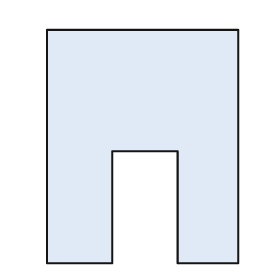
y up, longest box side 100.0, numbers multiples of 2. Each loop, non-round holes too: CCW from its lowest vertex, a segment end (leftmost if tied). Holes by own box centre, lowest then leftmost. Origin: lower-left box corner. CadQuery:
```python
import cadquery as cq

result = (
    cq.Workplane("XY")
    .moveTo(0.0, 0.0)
    .lineTo(28.0, 0.0)
    .lineTo(28.0, 48.0)
    .lineTo(56.0, 48.0)
    .lineTo(56.0, 0.0)
    .lineTo(82.0, 0.0)
    .lineTo(82.0, 100.0)
    .lineTo(0.0, 100.0)
    .close()
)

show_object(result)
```